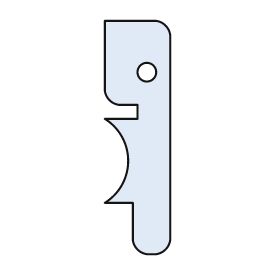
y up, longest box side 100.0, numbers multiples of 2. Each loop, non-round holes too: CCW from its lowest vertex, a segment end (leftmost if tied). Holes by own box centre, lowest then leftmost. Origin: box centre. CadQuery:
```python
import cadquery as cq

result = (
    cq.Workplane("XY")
    .moveTo(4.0, -50.0)
    .lineTo(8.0, -50.0)
    .threePointArc((12.0, -48.0), (14.0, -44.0))
    .lineTo(14.0, 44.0)
    .threePointArc((12.0, 48.0), (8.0, 50.0))
    .lineTo(-14.0, 50.0)
    .lineTo(-14.0, 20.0)
    .threePointArc((-12.0, 16.0), (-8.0, 14.0))
    .lineTo(0.0, 14.0)
    .lineTo(0.0, 8.0)
    .lineTo(-14.0, 8.0)
    .threePointArc((-4.0, -10.0), (-14.0, -28.0))
    .lineTo(-2.0, -28.0)
    .lineTo(-2.0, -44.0)
    .threePointArc((0.0, -48.0), (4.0, -50.0))
    .close()
    .moveTo(4.0, 28.0)
    .circle(4.0)
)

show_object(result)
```